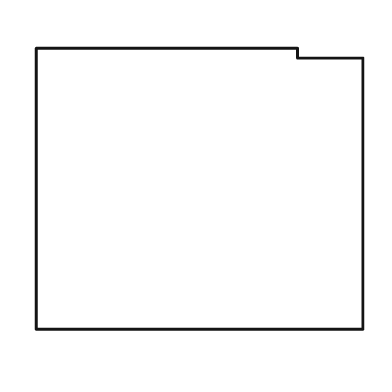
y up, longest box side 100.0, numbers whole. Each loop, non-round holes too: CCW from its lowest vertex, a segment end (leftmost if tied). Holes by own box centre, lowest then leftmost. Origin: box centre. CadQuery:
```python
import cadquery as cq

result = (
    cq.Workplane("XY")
    .moveTo(-50.0, -43.0)
    .lineTo(50.0, -43.0)
    .lineTo(50.0, 40.0)
    .lineTo(30.0, 40.0)
    .lineTo(30.0, 43.0)
    .lineTo(-50.0, 43.0)
    .close()
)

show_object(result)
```